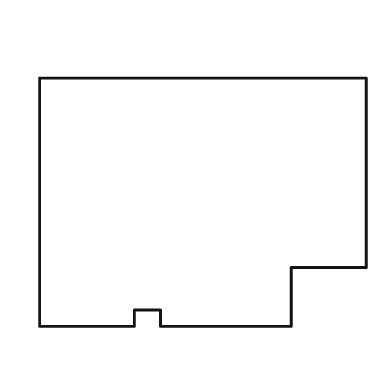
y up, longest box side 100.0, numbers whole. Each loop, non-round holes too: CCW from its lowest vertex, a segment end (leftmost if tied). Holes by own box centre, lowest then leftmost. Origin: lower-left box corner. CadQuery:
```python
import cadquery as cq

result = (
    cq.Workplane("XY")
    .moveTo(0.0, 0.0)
    .lineTo(29.0, 0.0)
    .lineTo(29.0, 5.0)
    .lineTo(37.0, 5.0)
    .lineTo(37.0, 0.0)
    .lineTo(77.0, 0.0)
    .lineTo(77.0, 18.0)
    .lineTo(100.0, 18.0)
    .lineTo(100.0, 76.0)
    .lineTo(0.0, 76.0)
    .close()
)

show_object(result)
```